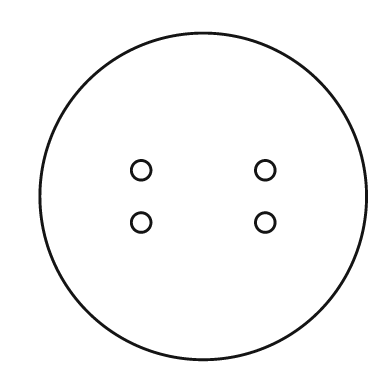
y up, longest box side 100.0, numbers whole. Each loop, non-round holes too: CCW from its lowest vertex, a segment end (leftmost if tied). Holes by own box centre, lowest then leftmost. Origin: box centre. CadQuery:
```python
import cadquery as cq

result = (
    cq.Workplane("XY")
    .moveTo(0.0, 0.0)
    .circle(50.0)
    .moveTo(-19.0, -8.0)
    .circle(3.0)
    .moveTo(19.0, -8.0)
    .circle(3.0)
    .moveTo(-19.0, 8.0)
    .circle(3.0)
    .moveTo(19.0, 8.0)
    .circle(3.0)
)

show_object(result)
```